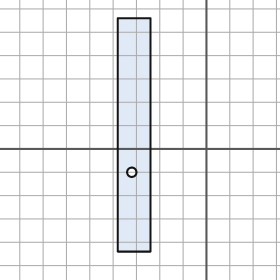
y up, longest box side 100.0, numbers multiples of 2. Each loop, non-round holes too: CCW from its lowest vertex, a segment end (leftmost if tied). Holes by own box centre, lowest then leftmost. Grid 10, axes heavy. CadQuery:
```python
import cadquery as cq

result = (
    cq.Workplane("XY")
    .moveTo(-38.0, -44.0)
    .lineTo(-24.0, -44.0)
    .lineTo(-24.0, 56.0)
    .lineTo(-38.0, 56.0)
    .close()
    .moveTo(-32.0, -10.0)
    .circle(2.0)
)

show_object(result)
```